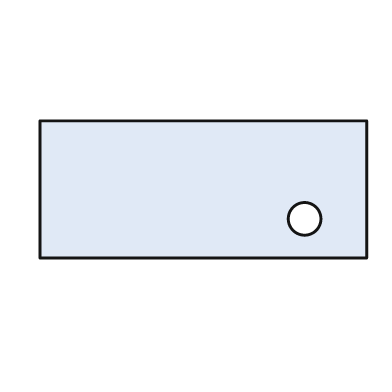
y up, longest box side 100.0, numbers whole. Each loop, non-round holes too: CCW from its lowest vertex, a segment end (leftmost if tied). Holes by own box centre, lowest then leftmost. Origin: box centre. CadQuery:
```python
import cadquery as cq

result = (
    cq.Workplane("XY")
    .moveTo(-50.0, -21.0)
    .lineTo(50.0, -21.0)
    .lineTo(50.0, 21.0)
    .lineTo(-50.0, 21.0)
    .close()
    .moveTo(31.0, -9.0)
    .circle(5.0)
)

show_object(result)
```